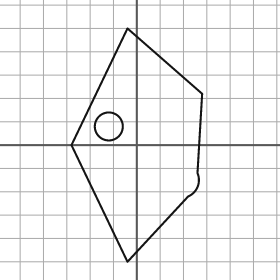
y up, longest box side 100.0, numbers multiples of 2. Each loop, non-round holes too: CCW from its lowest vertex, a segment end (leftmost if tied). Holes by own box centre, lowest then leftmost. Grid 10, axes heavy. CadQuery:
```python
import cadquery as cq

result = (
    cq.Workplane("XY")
    .moveTo(-4.0, -50.0)
    .lineTo(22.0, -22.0)
    .threePointArc((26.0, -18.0), (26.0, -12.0))
    .lineTo(28.0, 22.0)
    .lineTo(-4.0, 50.0)
    .lineTo(-28.0, 0.0)
    .close()
    .moveTo(-12.0, 8.0)
    .circle(6.0)
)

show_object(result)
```